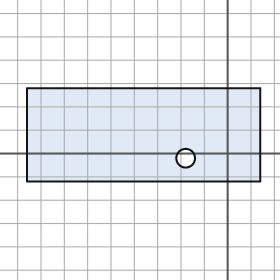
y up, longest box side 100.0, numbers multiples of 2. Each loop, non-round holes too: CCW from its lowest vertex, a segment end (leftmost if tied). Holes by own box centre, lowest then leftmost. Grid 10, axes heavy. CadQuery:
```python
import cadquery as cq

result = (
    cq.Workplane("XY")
    .moveTo(-86.0, -12.0)
    .lineTo(14.0, -12.0)
    .lineTo(14.0, 28.0)
    .lineTo(-86.0, 28.0)
    .close()
    .moveTo(-18.0, -2.0)
    .circle(4.0)
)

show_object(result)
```